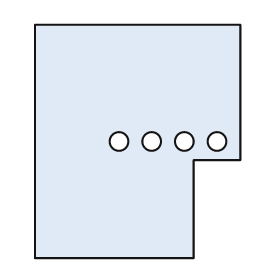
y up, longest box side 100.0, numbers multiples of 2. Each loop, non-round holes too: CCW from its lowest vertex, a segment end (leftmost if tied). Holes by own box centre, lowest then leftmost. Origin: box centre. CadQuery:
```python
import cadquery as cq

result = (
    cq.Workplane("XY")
    .moveTo(-44.0, -50.0)
    .lineTo(24.0, -50.0)
    .lineTo(24.0, -8.0)
    .lineTo(44.0, -8.0)
    .lineTo(44.0, 50.0)
    .lineTo(-44.0, 50.0)
    .close()
    .moveTo(-8.0, 0.0)
    .circle(4.0)
    .moveTo(6.0, 0.0)
    .circle(4.0)
    .moveTo(20.0, 0.0)
    .circle(4.0)
    .moveTo(34.0, 0.0)
    .circle(4.0)
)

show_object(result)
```